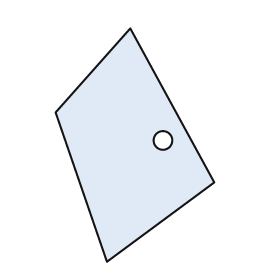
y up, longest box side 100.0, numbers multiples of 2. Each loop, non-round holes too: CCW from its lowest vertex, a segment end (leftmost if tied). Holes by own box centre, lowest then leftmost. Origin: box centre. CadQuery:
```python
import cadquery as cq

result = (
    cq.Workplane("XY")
    .moveTo(-12.0, -50.0)
    .lineTo(34.0, -16.0)
    .lineTo(-2.0, 50.0)
    .lineTo(-34.0, 14.0)
    .close()
    .moveTo(12.0, 2.0)
    .circle(4.0)
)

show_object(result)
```